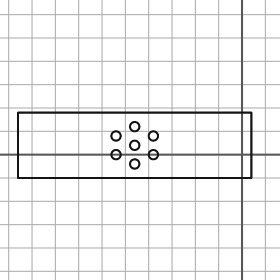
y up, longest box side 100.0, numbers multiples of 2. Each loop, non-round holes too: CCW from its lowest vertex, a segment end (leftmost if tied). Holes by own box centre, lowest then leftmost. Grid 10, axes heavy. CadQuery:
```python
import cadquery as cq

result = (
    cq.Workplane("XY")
    .moveTo(-96.0, -10.0)
    .lineTo(4.0, -10.0)
    .lineTo(4.0, 18.0)
    .lineTo(-96.0, 18.0)
    .close()
    .moveTo(-46.0, -4.0)
    .circle(2.0)
    .moveTo(-54.0, 0.0)
    .circle(2.0)
    .moveTo(-38.0, 0.0)
    .circle(2.0)
    .moveTo(-46.0, 4.0)
    .circle(2.0)
    .moveTo(-54.0, 8.0)
    .circle(2.0)
    .moveTo(-38.0, 8.0)
    .circle(2.0)
    .moveTo(-46.0, 12.0)
    .circle(2.0)
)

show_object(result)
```